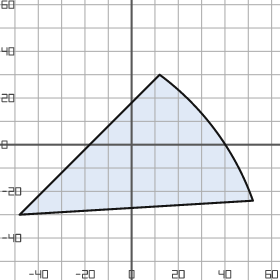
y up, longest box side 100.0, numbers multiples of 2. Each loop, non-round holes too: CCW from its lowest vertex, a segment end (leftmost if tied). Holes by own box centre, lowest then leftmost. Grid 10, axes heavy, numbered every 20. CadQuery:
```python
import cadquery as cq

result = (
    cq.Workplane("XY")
    .moveTo(-48.0, -30.0)
    .lineTo(52.0, -24.0)
    .threePointArc((36.0, 6.0), (12.0, 30.0))
    .close()
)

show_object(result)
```